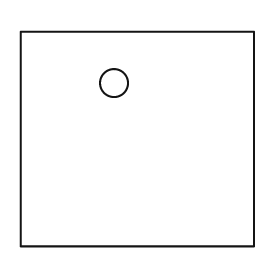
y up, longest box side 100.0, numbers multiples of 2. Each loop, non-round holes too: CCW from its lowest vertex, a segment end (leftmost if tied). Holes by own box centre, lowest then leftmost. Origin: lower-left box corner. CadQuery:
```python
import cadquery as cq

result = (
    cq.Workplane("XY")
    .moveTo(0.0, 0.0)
    .lineTo(100.0, 0.0)
    .lineTo(100.0, 92.0)
    .lineTo(0.0, 92.0)
    .close()
    .moveTo(40.0, 70.0)
    .circle(6.0)
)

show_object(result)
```